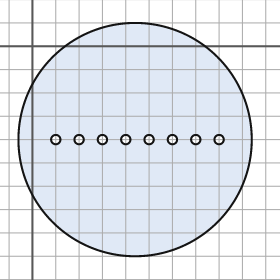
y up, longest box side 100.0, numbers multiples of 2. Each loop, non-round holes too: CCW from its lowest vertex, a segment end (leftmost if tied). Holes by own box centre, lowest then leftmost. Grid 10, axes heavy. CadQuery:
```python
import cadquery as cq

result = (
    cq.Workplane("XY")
    .moveTo(44.0, -40.0)
    .circle(50.0)
    .moveTo(10.0, -40.0)
    .circle(2.0)
    .moveTo(20.0, -40.0)
    .circle(2.0)
    .moveTo(30.0, -40.0)
    .circle(2.0)
    .moveTo(40.0, -40.0)
    .circle(2.0)
    .moveTo(50.0, -40.0)
    .circle(2.0)
    .moveTo(60.0, -40.0)
    .circle(2.0)
    .moveTo(70.0, -40.0)
    .circle(2.0)
    .moveTo(80.0, -40.0)
    .circle(2.0)
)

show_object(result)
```